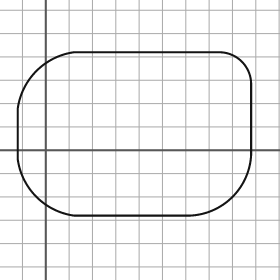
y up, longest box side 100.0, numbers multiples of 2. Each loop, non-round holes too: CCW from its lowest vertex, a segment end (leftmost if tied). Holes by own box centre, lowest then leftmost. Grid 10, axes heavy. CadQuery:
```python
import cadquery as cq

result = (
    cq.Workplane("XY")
    .moveTo(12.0, -28.0)
    .lineTo(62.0, -28.0)
    .threePointArc((80.0, -20.0), (88.0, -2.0))
    .lineTo(88.0, 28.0)
    .threePointArc((84.0, 38.0), (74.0, 42.0))
    .lineTo(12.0, 42.0)
    .threePointArc((-4.0, 34.0), (-12.0, 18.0))
    .lineTo(-12.0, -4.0)
    .threePointArc((-4.0, -20.0), (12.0, -28.0))
    .close()
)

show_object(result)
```